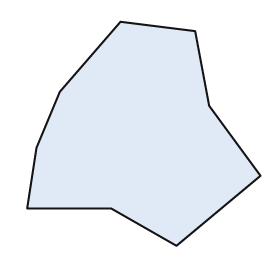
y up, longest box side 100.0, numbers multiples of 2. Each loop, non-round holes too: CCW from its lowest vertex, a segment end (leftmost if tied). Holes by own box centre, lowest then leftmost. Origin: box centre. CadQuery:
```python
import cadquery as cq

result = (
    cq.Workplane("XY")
    .moveTo(14.0, -48.0)
    .lineTo(50.0, -18.0)
    .lineTo(28.0, 12.0)
    .lineTo(22.0, 44.0)
    .lineTo(-10.0, 48.0)
    .lineTo(-36.0, 18.0)
    .lineTo(-46.0, -6.0)
    .lineTo(-50.0, -32.0)
    .lineTo(-14.0, -32.0)
    .close()
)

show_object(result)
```